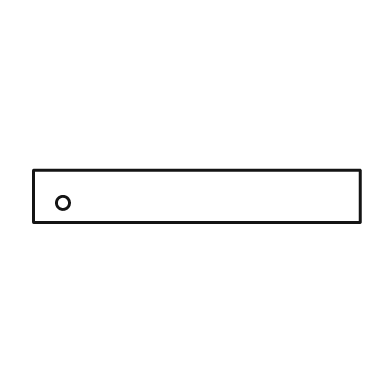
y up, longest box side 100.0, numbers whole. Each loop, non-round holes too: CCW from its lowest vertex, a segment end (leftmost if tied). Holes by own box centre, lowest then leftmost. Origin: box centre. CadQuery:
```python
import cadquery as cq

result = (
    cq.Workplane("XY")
    .moveTo(-50.0, -8.0)
    .lineTo(50.0, -8.0)
    .lineTo(50.0, 8.0)
    .lineTo(-50.0, 8.0)
    .close()
    .moveTo(-41.0, -2.0)
    .circle(2.0)
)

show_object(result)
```